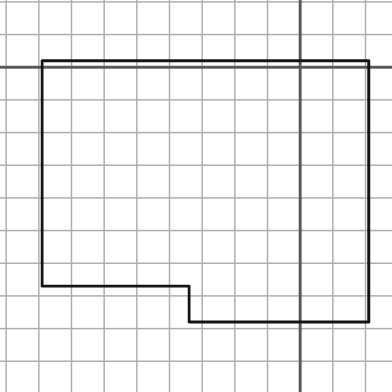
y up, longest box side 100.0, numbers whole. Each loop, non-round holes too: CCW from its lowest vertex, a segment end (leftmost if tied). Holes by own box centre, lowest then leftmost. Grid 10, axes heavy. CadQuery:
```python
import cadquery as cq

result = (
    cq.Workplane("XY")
    .moveTo(-34.0, -78.0)
    .lineTo(21.0, -78.0)
    .lineTo(21.0, 2.0)
    .lineTo(-79.0, 2.0)
    .lineTo(-79.0, -67.0)
    .lineTo(-34.0, -67.0)
    .close()
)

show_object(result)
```